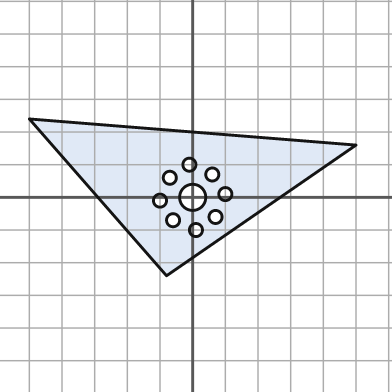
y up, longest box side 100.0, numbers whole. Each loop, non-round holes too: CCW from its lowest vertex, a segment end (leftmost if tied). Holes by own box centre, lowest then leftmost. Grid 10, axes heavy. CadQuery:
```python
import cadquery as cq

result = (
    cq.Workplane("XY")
    .moveTo(-8.0, -24.0)
    .lineTo(50.0, 16.0)
    .lineTo(-50.0, 24.0)
    .close()
    .moveTo(1.0, -10.0)
    .circle(2.0)
    .moveTo(-6.0, -7.0)
    .circle(2.0)
    .moveTo(7.0, -6.0)
    .circle(2.0)
    .moveTo(-10.0, -1.0)
    .circle(2.0)
    .moveTo(0.0, 0.0)
    .circle(4.0)
    .moveTo(10.0, 1.0)
    .circle(2.0)
    .moveTo(-7.0, 6.0)
    .circle(2.0)
    .moveTo(6.0, 7.0)
    .circle(2.0)
    .moveTo(-1.0, 10.0)
    .circle(2.0)
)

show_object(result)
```